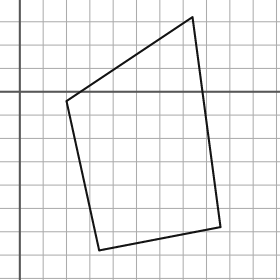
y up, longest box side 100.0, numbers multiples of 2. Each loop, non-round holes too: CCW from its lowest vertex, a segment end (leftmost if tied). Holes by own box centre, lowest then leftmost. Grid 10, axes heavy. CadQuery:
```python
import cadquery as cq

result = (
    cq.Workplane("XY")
    .moveTo(34.0, -68.0)
    .lineTo(86.0, -58.0)
    .lineTo(74.0, 32.0)
    .lineTo(20.0, -4.0)
    .close()
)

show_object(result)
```